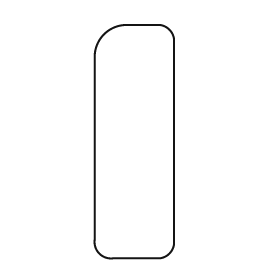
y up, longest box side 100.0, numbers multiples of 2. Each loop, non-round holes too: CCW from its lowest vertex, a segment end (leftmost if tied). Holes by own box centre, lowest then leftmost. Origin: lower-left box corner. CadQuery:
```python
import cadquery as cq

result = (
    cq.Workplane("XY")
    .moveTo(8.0, 0.0)
    .lineTo(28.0, 0.0)
    .threePointArc((32.0, 2.0), (34.0, 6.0))
    .lineTo(34.0, 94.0)
    .threePointArc((32.0, 98.0), (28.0, 100.0))
    .lineTo(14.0, 100.0)
    .threePointArc((4.0, 96.0), (0.0, 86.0))
    .lineTo(0.0, 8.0)
    .threePointArc((2.0, 2.0), (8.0, 0.0))
    .close()
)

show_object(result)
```